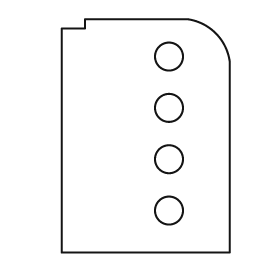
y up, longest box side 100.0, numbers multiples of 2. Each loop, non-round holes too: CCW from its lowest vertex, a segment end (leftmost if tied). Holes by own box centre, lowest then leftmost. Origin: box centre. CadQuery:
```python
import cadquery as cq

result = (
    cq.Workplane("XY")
    .moveTo(-36.0, -50.0)
    .lineTo(36.0, -50.0)
    .lineTo(36.0, 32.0)
    .threePointArc((30.0, 44.0), (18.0, 50.0))
    .lineTo(-26.0, 50.0)
    .lineTo(-26.0, 46.0)
    .lineTo(-36.0, 46.0)
    .close()
    .moveTo(10.0, -32.0)
    .circle(6.0)
    .moveTo(10.0, -10.0)
    .circle(6.0)
    .moveTo(10.0, 12.0)
    .circle(6.0)
    .moveTo(10.0, 34.0)
    .circle(6.0)
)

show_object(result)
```